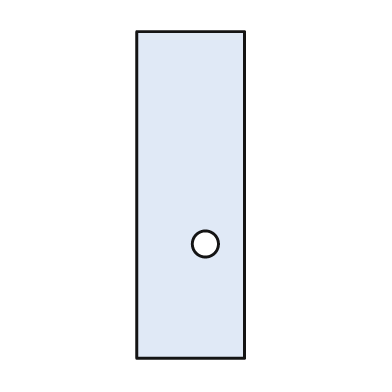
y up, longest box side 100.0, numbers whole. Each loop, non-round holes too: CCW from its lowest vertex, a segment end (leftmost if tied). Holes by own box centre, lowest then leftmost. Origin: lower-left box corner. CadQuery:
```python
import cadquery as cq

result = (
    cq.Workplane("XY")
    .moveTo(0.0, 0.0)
    .lineTo(33.0, 0.0)
    .lineTo(33.0, 100.0)
    .lineTo(0.0, 100.0)
    .close()
    .moveTo(21.0, 35.0)
    .circle(4.0)
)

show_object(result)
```